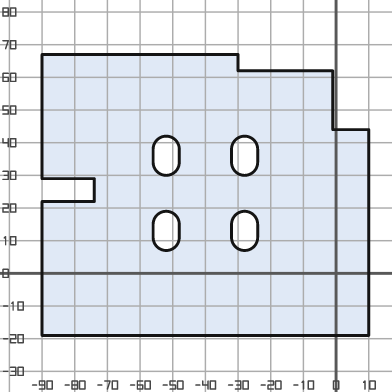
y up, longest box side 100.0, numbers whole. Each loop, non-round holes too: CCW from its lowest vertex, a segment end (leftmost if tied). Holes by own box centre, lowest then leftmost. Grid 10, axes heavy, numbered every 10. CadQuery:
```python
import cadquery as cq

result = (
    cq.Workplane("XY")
    .moveTo(-90.0, -19.0)
    .lineTo(10.0, -19.0)
    .lineTo(10.0, 44.0)
    .lineTo(-1.0, 44.0)
    .lineTo(-1.0, 62.0)
    .lineTo(-30.0, 62.0)
    .lineTo(-30.0, 67.0)
    .lineTo(-90.0, 67.0)
    .lineTo(-90.0, 29.0)
    .lineTo(-74.0, 29.0)
    .lineTo(-74.0, 22.0)
    .lineTo(-90.0, 22.0)
    .close()
    .moveTo(-56.0, 11.0)
    .threePointArc((-52.0, 7.0), (-48.0, 11.0))
    .lineTo(-48.0, 15.0)
    .threePointArc((-52.0, 19.0), (-56.0, 15.0))
    .close()
    .moveTo(-32.0, 11.0)
    .threePointArc((-28.0, 7.0), (-24.0, 11.0))
    .lineTo(-24.0, 15.0)
    .threePointArc((-28.0, 19.0), (-32.0, 15.0))
    .close()
    .moveTo(-56.0, 34.0)
    .threePointArc((-52.0, 30.0), (-48.0, 34.0))
    .lineTo(-48.0, 38.0)
    .threePointArc((-52.0, 42.0), (-56.0, 38.0))
    .close()
    .moveTo(-32.0, 34.0)
    .threePointArc((-28.0, 30.0), (-24.0, 34.0))
    .lineTo(-24.0, 38.0)
    .threePointArc((-28.0, 42.0), (-32.0, 38.0))
    .close()
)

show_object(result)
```